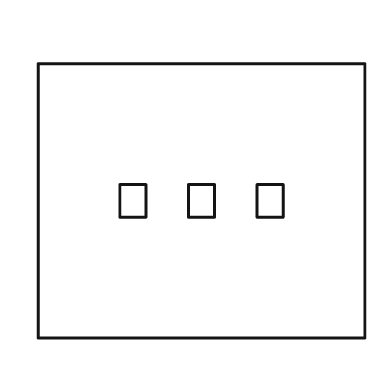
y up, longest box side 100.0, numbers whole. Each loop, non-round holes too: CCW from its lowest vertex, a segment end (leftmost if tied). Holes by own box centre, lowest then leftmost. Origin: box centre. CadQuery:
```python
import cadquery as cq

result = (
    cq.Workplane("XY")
    .moveTo(-50.0, -42.0)
    .lineTo(50.0, -42.0)
    .lineTo(50.0, 42.0)
    .lineTo(-50.0, 42.0)
    .close()
    .moveTo(-25.0, -5.0)
    .lineTo(-17.0, -5.0)
    .lineTo(-17.0, 5.0)
    .lineTo(-25.0, 5.0)
    .close()
    .moveTo(-4.0, -5.0)
    .lineTo(4.0, -5.0)
    .lineTo(4.0, 5.0)
    .lineTo(-4.0, 5.0)
    .close()
    .moveTo(17.0, -5.0)
    .lineTo(25.0, -5.0)
    .lineTo(25.0, 5.0)
    .lineTo(17.0, 5.0)
    .close()
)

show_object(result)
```